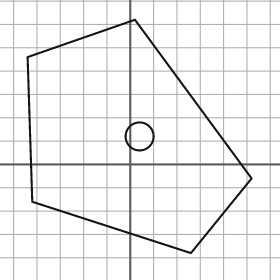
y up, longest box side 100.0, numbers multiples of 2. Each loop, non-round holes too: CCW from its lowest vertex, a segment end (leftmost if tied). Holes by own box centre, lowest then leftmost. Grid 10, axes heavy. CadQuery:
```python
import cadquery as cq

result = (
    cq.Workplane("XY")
    .moveTo(26.0, -38.0)
    .lineTo(52.0, -6.0)
    .lineTo(2.0, 62.0)
    .lineTo(-44.0, 46.0)
    .lineTo(-42.0, -16.0)
    .close()
    .moveTo(4.0, 12.0)
    .circle(6.0)
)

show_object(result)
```